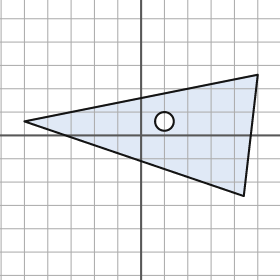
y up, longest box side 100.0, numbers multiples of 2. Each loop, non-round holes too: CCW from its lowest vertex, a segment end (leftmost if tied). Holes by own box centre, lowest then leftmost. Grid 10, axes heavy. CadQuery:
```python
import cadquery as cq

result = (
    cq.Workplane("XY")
    .moveTo(44.0, -26.0)
    .lineTo(50.0, 26.0)
    .lineTo(-50.0, 6.0)
    .close()
    .moveTo(10.0, 6.0)
    .circle(4.0)
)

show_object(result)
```